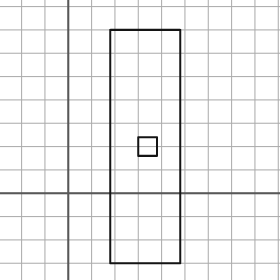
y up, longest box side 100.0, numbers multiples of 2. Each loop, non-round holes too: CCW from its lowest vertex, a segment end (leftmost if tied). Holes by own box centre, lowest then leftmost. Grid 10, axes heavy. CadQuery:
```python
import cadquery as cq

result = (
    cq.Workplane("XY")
    .moveTo(18.0, -30.0)
    .lineTo(48.0, -30.0)
    .lineTo(48.0, 70.0)
    .lineTo(18.0, 70.0)
    .close()
    .moveTo(30.0, 16.0)
    .lineTo(38.0, 16.0)
    .lineTo(38.0, 24.0)
    .lineTo(30.0, 24.0)
    .close()
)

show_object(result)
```